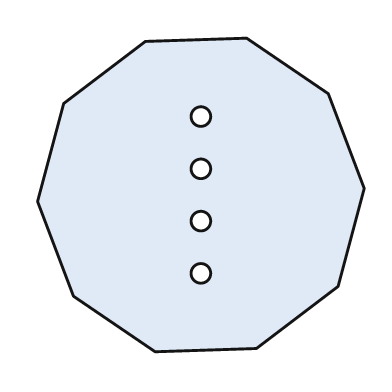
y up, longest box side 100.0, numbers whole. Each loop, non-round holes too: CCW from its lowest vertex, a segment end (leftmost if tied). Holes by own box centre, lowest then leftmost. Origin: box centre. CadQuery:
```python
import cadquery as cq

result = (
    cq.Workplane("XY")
    .moveTo(-14.0, -48.0)
    .lineTo(17.0, -47.0)
    .lineTo(42.0, -28.0)
    .lineTo(50.0, 2.0)
    .lineTo(39.0, 31.0)
    .lineTo(14.0, 48.0)
    .lineTo(-17.0, 47.0)
    .lineTo(-42.0, 28.0)
    .lineTo(-50.0, -2.0)
    .lineTo(-39.0, -31.0)
    .close()
    .moveTo(0.0, -24.0)
    .circle(3.0)
    .moveTo(0.0, -8.0)
    .circle(3.0)
    .moveTo(0.0, 8.0)
    .circle(3.0)
    .moveTo(0.0, 24.0)
    .circle(3.0)
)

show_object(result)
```